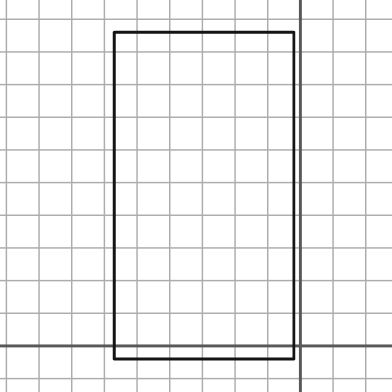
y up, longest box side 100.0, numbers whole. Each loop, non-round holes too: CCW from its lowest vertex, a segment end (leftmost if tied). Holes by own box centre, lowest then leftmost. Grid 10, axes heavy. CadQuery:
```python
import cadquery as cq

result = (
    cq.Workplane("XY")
    .moveTo(-57.0, -4.0)
    .lineTo(-2.0, -4.0)
    .lineTo(-2.0, 96.0)
    .lineTo(-57.0, 96.0)
    .close()
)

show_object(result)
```